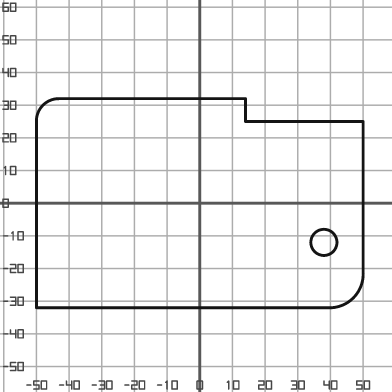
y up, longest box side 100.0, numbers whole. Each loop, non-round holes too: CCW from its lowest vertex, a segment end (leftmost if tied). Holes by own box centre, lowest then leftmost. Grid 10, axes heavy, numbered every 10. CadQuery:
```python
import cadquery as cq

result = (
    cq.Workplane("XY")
    .moveTo(-50.0, -32.0)
    .lineTo(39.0, -32.0)
    .threePointArc((47.0, -29.0), (50.0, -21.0))
    .lineTo(50.0, 25.0)
    .lineTo(14.0, 25.0)
    .lineTo(14.0, 32.0)
    .lineTo(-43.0, 32.0)
    .threePointArc((-48.0, 30.0), (-50.0, 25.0))
    .close()
    .moveTo(38.0, -12.0)
    .circle(4.0)
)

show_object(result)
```